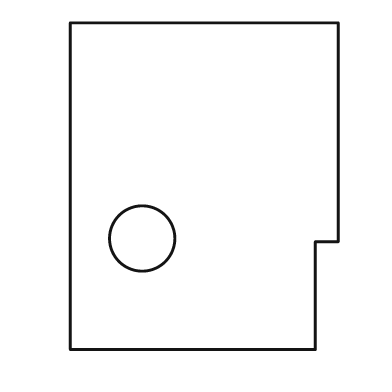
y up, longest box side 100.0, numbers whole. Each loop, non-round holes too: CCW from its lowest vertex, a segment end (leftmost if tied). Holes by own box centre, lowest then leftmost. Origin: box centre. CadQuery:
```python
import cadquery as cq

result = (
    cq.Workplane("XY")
    .moveTo(-41.0, -50.0)
    .lineTo(34.0, -50.0)
    .lineTo(34.0, -17.0)
    .lineTo(41.0, -17.0)
    .lineTo(41.0, 50.0)
    .lineTo(-41.0, 50.0)
    .close()
    .moveTo(-19.0, -16.0)
    .circle(10.0)
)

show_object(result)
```